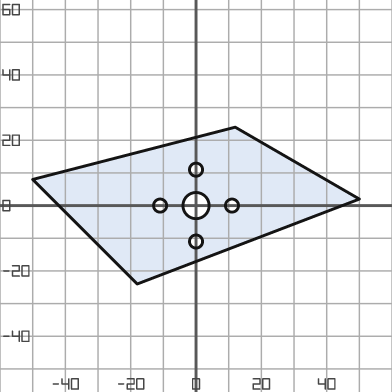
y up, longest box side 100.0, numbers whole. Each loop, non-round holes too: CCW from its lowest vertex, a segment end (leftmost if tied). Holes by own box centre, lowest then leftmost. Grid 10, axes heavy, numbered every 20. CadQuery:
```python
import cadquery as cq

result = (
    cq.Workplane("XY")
    .moveTo(-18.0, -24.0)
    .lineTo(50.0, 2.0)
    .lineTo(12.0, 24.0)
    .lineTo(-50.0, 8.0)
    .close()
    .moveTo(0.0, -11.0)
    .circle(2.0)
    .moveTo(-11.0, 0.0)
    .circle(2.0)
    .moveTo(0.0, 0.0)
    .circle(4.0)
    .moveTo(11.0, 0.0)
    .circle(2.0)
    .moveTo(0.0, 11.0)
    .circle(2.0)
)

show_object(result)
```